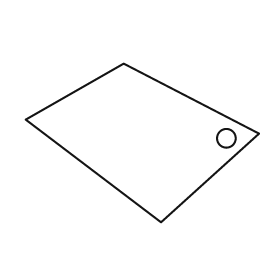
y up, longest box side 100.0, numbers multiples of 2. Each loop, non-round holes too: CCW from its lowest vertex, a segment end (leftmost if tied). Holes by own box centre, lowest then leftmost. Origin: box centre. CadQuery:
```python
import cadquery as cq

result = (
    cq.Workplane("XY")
    .moveTo(8.0, -34.0)
    .lineTo(50.0, 4.0)
    .lineTo(-8.0, 34.0)
    .lineTo(-50.0, 10.0)
    .close()
    .moveTo(36.0, 2.0)
    .circle(4.0)
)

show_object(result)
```